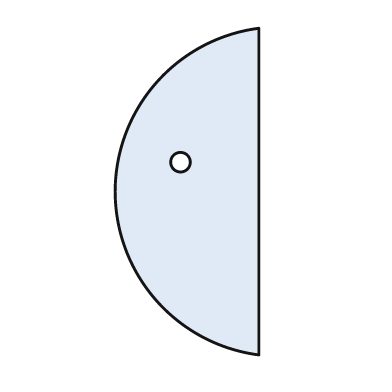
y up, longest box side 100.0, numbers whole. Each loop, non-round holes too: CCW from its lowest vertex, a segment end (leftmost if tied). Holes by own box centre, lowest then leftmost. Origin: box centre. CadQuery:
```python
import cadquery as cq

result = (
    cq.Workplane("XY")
    .moveTo(22.0, -50.0)
    .lineTo(22.0, 50.0)
    .threePointArc((-22.0, 0.0), (22.0, -50.0))
    .close()
    .moveTo(-2.0, 9.0)
    .circle(3.0)
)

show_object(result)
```